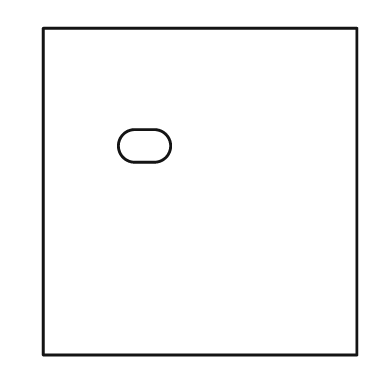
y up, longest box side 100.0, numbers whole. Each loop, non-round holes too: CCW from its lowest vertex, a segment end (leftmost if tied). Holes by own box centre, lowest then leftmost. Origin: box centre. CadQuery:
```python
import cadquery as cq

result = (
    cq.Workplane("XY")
    .moveTo(-48.0, -50.0)
    .lineTo(48.0, -50.0)
    .lineTo(48.0, 50.0)
    .lineTo(-48.0, 50.0)
    .close()
    .moveTo(-20.0, 9.0)
    .lineTo(-14.0, 9.0)
    .threePointArc((-9.0, 14.0), (-14.0, 19.0))
    .lineTo(-20.0, 19.0)
    .threePointArc((-25.0, 14.0), (-20.0, 9.0))
    .close()
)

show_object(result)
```